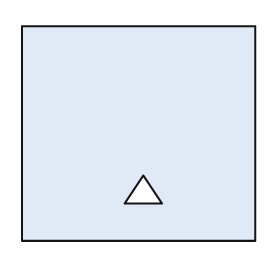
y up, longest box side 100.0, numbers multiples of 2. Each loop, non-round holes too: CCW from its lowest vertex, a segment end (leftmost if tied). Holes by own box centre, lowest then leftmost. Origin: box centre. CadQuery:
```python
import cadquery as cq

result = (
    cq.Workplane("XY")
    .moveTo(-50.0, -46.0)
    .lineTo(50.0, -46.0)
    .lineTo(50.0, 46.0)
    .lineTo(-50.0, 46.0)
    .close()
    .moveTo(-6.0, -30.0)
    .lineTo(10.0, -30.0)
    .lineTo(2.0, -18.0)
    .close()
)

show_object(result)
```